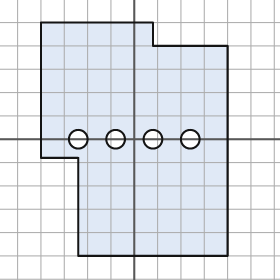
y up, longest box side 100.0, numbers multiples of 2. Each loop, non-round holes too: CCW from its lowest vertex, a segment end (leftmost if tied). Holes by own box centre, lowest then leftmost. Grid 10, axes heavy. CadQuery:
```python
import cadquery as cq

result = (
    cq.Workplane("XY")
    .moveTo(-24.0, -50.0)
    .lineTo(40.0, -50.0)
    .lineTo(40.0, 40.0)
    .lineTo(8.0, 40.0)
    .lineTo(8.0, 50.0)
    .lineTo(-40.0, 50.0)
    .lineTo(-40.0, -8.0)
    .lineTo(-24.0, -8.0)
    .close()
    .moveTo(-24.0, 0.0)
    .circle(4.0)
    .moveTo(-8.0, 0.0)
    .circle(4.0)
    .moveTo(8.0, 0.0)
    .circle(4.0)
    .moveTo(24.0, 0.0)
    .circle(4.0)
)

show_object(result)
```